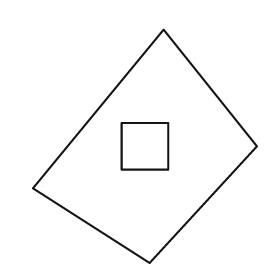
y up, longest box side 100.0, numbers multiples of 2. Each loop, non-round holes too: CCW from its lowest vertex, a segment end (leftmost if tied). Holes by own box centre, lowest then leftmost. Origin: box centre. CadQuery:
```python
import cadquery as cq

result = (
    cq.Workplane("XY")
    .moveTo(2.0, -50.0)
    .lineTo(48.0, 0.0)
    .lineTo(8.0, 50.0)
    .lineTo(-48.0, -18.0)
    .close()
    .moveTo(-10.0, -10.0)
    .lineTo(10.0, -10.0)
    .lineTo(10.0, 10.0)
    .lineTo(-10.0, 10.0)
    .close()
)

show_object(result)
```